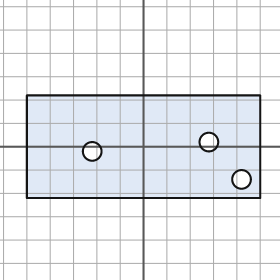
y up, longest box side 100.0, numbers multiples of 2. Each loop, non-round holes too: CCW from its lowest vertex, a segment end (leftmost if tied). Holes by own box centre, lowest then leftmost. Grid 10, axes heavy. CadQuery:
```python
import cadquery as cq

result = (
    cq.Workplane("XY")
    .moveTo(-50.0, -22.0)
    .lineTo(50.0, -22.0)
    .lineTo(50.0, 22.0)
    .lineTo(-50.0, 22.0)
    .close()
    .moveTo(42.0, -14.0)
    .circle(4.0)
    .moveTo(-22.0, -2.0)
    .circle(4.0)
    .moveTo(28.0, 2.0)
    .circle(4.0)
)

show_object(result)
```